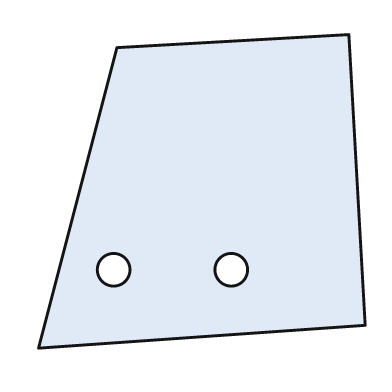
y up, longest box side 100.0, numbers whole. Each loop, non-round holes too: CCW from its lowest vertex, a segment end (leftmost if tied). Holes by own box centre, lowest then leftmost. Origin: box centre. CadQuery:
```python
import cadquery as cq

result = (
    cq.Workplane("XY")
    .moveTo(-50.0, -48.0)
    .lineTo(50.0, -41.0)
    .lineTo(45.0, 48.0)
    .lineTo(-26.0, 44.0)
    .close()
    .moveTo(-27.0, -24.0)
    .circle(5.0)
    .moveTo(9.0, -24.0)
    .circle(5.0)
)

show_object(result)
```